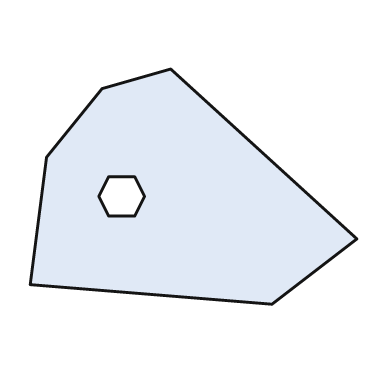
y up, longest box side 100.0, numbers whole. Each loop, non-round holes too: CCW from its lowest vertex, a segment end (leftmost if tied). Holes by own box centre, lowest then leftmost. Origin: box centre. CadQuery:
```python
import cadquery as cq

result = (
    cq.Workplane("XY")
    .moveTo(24.0, -36.0)
    .lineTo(50.0, -16.0)
    .lineTo(-7.0, 36.0)
    .lineTo(-28.0, 30.0)
    .lineTo(-45.0, 9.0)
    .lineTo(-50.0, -30.0)
    .close()
    .moveTo(-26.0, -9.0)
    .lineTo(-18.0, -9.0)
    .lineTo(-15.0, -3.0)
    .lineTo(-18.0, 3.0)
    .lineTo(-26.0, 3.0)
    .lineTo(-29.0, -3.0)
    .close()
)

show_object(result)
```